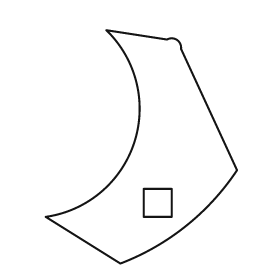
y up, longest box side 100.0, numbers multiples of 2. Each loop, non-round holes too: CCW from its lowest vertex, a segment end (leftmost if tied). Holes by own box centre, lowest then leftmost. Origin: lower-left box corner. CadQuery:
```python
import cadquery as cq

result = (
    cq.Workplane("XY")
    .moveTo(32.0, 0.0)
    .threePointArc((60.0, 16.0), (82.0, 40.0))
    .lineTo(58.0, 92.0)
    .threePointArc((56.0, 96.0), (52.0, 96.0))
    .lineTo(26.0, 100.0)
    .threePointArc((38.0, 52.0), (0.0, 20.0))
    .close()
    .moveTo(42.0, 20.0)
    .lineTo(54.0, 20.0)
    .lineTo(54.0, 32.0)
    .lineTo(42.0, 32.0)
    .close()
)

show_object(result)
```